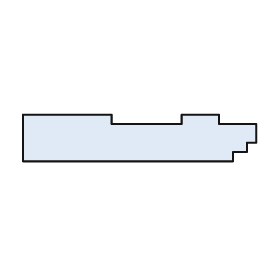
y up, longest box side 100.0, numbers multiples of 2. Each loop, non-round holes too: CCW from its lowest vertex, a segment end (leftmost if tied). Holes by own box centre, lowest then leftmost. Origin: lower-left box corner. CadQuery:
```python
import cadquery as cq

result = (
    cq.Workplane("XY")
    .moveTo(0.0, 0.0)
    .lineTo(90.0, 0.0)
    .lineTo(90.0, 4.0)
    .lineTo(96.0, 4.0)
    .lineTo(96.0, 8.0)
    .lineTo(100.0, 8.0)
    .lineTo(100.0, 16.0)
    .lineTo(84.0, 16.0)
    .lineTo(84.0, 20.0)
    .lineTo(68.0, 20.0)
    .lineTo(68.0, 16.0)
    .lineTo(38.0, 16.0)
    .lineTo(38.0, 20.0)
    .lineTo(0.0, 20.0)
    .close()
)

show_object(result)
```